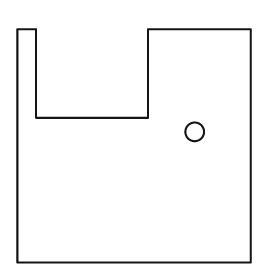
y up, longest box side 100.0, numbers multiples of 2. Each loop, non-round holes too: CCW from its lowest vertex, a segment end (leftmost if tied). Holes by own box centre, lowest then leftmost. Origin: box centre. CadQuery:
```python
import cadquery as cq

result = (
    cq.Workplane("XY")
    .moveTo(-50.0, -50.0)
    .lineTo(50.0, -50.0)
    .lineTo(50.0, 50.0)
    .lineTo(6.0, 50.0)
    .lineTo(6.0, 12.0)
    .lineTo(-42.0, 12.0)
    .lineTo(-42.0, 50.0)
    .lineTo(-50.0, 50.0)
    .close()
    .moveTo(26.0, 6.0)
    .circle(4.0)
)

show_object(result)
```